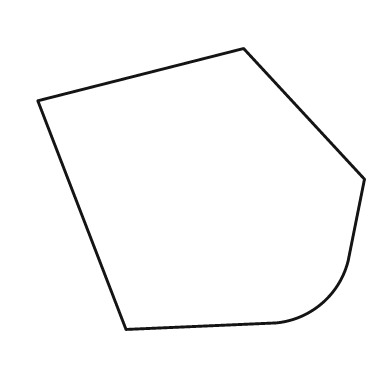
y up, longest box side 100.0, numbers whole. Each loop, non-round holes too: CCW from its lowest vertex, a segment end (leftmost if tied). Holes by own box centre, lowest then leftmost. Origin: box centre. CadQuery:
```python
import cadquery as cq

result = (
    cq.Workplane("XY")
    .moveTo(-23.0, -43.0)
    .lineTo(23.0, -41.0)
    .threePointArc((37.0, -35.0), (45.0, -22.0))
    .lineTo(50.0, 3.0)
    .lineTo(13.0, 43.0)
    .lineTo(-50.0, 27.0)
    .close()
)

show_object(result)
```